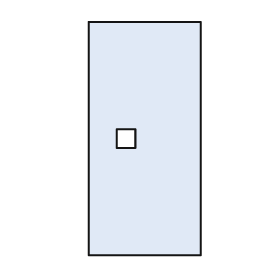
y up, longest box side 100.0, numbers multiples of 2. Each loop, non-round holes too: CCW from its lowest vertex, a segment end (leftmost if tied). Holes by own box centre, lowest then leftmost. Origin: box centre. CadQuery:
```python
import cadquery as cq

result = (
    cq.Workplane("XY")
    .moveTo(-24.0, -50.0)
    .lineTo(24.0, -50.0)
    .lineTo(24.0, 50.0)
    .lineTo(-24.0, 50.0)
    .close()
    .moveTo(-12.0, -4.0)
    .lineTo(-4.0, -4.0)
    .lineTo(-4.0, 4.0)
    .lineTo(-12.0, 4.0)
    .close()
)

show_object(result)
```